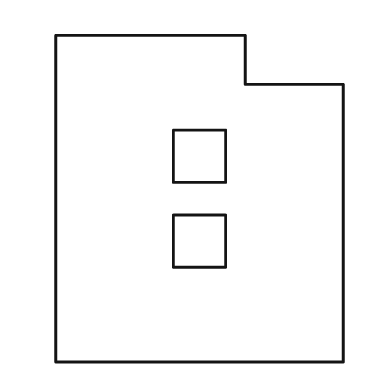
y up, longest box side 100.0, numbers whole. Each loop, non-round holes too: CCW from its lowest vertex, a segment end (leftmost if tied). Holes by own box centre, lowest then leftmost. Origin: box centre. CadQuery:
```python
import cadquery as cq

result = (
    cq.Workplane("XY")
    .moveTo(-44.0, -50.0)
    .lineTo(44.0, -50.0)
    .lineTo(44.0, 35.0)
    .lineTo(14.0, 35.0)
    .lineTo(14.0, 50.0)
    .lineTo(-44.0, 50.0)
    .close()
    .moveTo(-8.0, -21.0)
    .lineTo(8.0, -21.0)
    .lineTo(8.0, -5.0)
    .lineTo(-8.0, -5.0)
    .close()
    .moveTo(-8.0, 5.0)
    .lineTo(8.0, 5.0)
    .lineTo(8.0, 21.0)
    .lineTo(-8.0, 21.0)
    .close()
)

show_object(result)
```